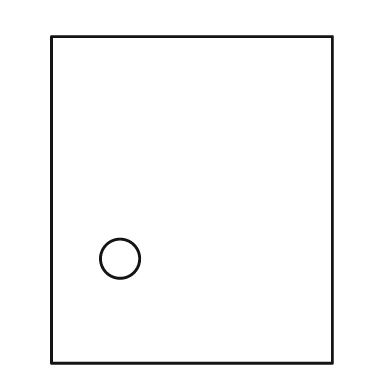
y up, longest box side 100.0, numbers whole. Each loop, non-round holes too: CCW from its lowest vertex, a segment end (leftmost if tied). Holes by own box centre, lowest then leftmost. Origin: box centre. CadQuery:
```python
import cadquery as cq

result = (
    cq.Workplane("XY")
    .moveTo(-43.0, -50.0)
    .lineTo(43.0, -50.0)
    .lineTo(43.0, 50.0)
    .lineTo(-43.0, 50.0)
    .close()
    .moveTo(-22.0, -18.0)
    .circle(6.0)
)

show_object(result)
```